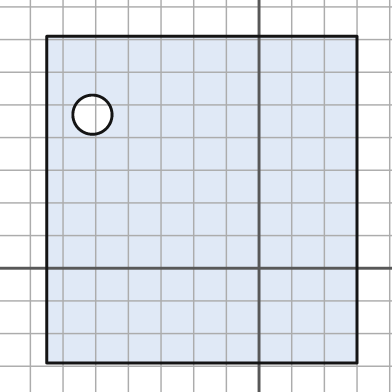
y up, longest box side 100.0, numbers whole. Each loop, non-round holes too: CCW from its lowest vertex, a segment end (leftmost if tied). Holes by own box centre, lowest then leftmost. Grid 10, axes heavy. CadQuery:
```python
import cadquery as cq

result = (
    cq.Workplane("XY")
    .moveTo(-65.0, -29.0)
    .lineTo(30.0, -29.0)
    .lineTo(30.0, 71.0)
    .lineTo(-65.0, 71.0)
    .close()
    .moveTo(-51.0, 47.0)
    .circle(6.0)
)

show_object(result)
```